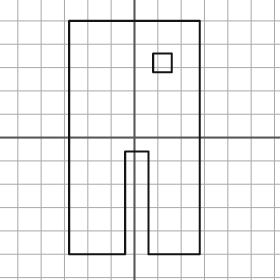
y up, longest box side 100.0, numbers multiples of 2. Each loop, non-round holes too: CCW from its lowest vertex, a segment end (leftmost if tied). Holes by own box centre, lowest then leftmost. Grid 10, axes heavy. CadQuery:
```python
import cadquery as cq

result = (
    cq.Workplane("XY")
    .moveTo(-28.0, -50.0)
    .lineTo(-4.0, -50.0)
    .lineTo(-4.0, -6.0)
    .lineTo(6.0, -6.0)
    .lineTo(6.0, -50.0)
    .lineTo(28.0, -50.0)
    .lineTo(28.0, 50.0)
    .lineTo(-28.0, 50.0)
    .close()
    .moveTo(8.0, 28.0)
    .lineTo(16.0, 28.0)
    .lineTo(16.0, 36.0)
    .lineTo(8.0, 36.0)
    .close()
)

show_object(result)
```